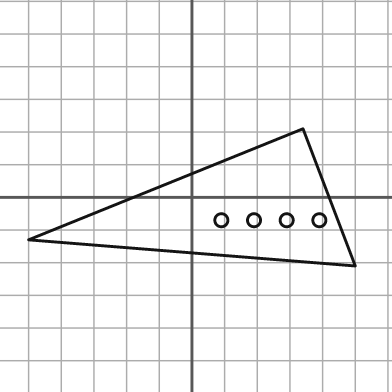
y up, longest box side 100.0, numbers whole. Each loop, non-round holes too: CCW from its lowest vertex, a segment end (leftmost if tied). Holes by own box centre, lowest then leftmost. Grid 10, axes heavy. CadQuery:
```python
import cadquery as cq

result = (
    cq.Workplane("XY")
    .moveTo(50.0, -21.0)
    .lineTo(34.0, 21.0)
    .lineTo(-50.0, -13.0)
    .close()
    .moveTo(9.0, -7.0)
    .circle(2.0)
    .moveTo(19.0, -7.0)
    .circle(2.0)
    .moveTo(29.0, -7.0)
    .circle(2.0)
    .moveTo(39.0, -7.0)
    .circle(2.0)
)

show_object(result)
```